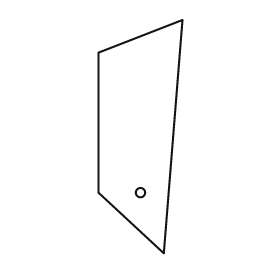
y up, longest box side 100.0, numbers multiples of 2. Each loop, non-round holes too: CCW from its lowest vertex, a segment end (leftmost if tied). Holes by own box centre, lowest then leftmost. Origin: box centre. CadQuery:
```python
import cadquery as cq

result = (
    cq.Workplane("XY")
    .moveTo(10.0, -50.0)
    .lineTo(18.0, 50.0)
    .lineTo(-18.0, 36.0)
    .lineTo(-18.0, -24.0)
    .close()
    .moveTo(0.0, -24.0)
    .circle(2.0)
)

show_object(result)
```